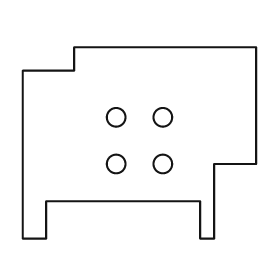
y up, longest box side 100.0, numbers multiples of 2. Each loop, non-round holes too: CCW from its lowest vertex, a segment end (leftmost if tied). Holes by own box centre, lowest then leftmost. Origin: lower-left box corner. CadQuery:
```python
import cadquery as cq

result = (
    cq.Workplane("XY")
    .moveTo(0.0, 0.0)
    .lineTo(10.0, 0.0)
    .lineTo(10.0, 16.0)
    .lineTo(76.0, 16.0)
    .lineTo(76.0, 0.0)
    .lineTo(82.0, 0.0)
    .lineTo(82.0, 32.0)
    .lineTo(100.0, 32.0)
    .lineTo(100.0, 82.0)
    .lineTo(22.0, 82.0)
    .lineTo(22.0, 72.0)
    .lineTo(0.0, 72.0)
    .close()
    .moveTo(40.0, 32.0)
    .circle(4.0)
    .moveTo(60.0, 32.0)
    .circle(4.0)
    .moveTo(40.0, 52.0)
    .circle(4.0)
    .moveTo(60.0, 52.0)
    .circle(4.0)
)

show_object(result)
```